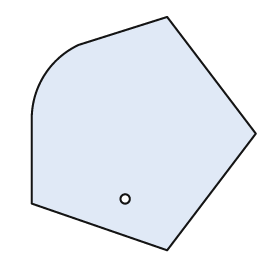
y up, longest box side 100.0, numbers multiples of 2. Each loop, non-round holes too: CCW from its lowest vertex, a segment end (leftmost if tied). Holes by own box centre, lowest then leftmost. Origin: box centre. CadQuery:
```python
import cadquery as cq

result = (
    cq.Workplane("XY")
    .moveTo(10.0, -50.0)
    .lineTo(48.0, 0.0)
    .lineTo(10.0, 50.0)
    .lineTo(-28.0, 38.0)
    .threePointArc((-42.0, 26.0), (-48.0, 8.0))
    .lineTo(-48.0, -30.0)
    .close()
    .moveTo(-8.0, -28.0)
    .circle(2.0)
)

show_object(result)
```